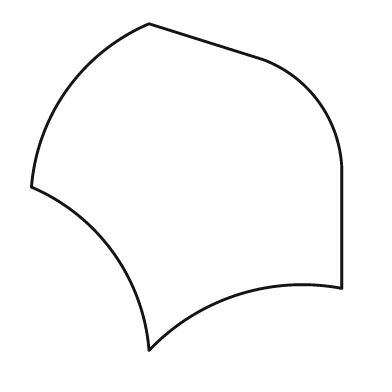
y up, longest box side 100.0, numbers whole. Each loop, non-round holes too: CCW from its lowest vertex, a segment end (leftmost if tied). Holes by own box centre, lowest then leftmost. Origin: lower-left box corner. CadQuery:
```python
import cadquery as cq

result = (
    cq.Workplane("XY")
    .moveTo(36.0, 0.0)
    .threePointArc((63.0, 17.0), (95.0, 19.0))
    .lineTo(95.0, 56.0)
    .threePointArc((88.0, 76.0), (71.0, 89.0))
    .lineTo(36.0, 100.0)
    .threePointArc((11.0, 80.0), (0.0, 50.0))
    .threePointArc((25.0, 30.0), (36.0, 0.0))
    .close()
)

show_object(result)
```